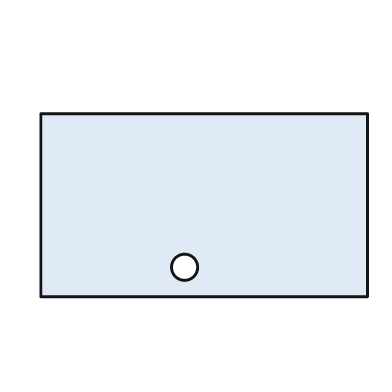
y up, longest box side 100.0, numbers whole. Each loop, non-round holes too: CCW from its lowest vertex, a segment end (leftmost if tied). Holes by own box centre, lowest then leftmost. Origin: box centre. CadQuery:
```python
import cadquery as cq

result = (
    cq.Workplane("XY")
    .moveTo(-50.0, -28.0)
    .lineTo(50.0, -28.0)
    .lineTo(50.0, 28.0)
    .lineTo(-50.0, 28.0)
    .close()
    .moveTo(-6.0, -19.0)
    .circle(4.0)
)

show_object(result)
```